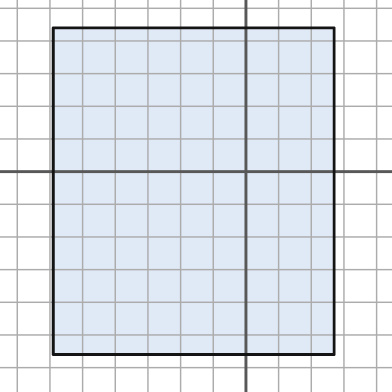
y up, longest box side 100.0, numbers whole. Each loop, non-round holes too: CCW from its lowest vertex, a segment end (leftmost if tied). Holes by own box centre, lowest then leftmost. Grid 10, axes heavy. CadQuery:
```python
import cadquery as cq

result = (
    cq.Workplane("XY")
    .moveTo(-59.0, -56.0)
    .lineTo(27.0, -56.0)
    .lineTo(27.0, 44.0)
    .lineTo(-59.0, 44.0)
    .close()
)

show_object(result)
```